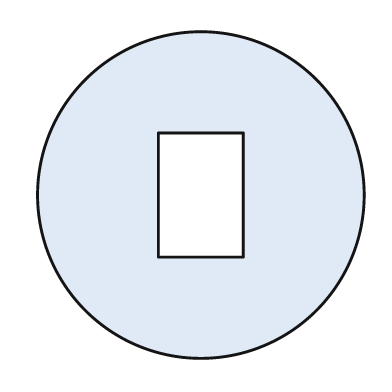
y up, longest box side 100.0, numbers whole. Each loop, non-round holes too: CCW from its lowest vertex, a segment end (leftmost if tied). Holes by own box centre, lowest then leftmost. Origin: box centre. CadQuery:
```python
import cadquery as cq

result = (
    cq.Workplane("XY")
    .moveTo(0.0, 0.0)
    .circle(50.0)
    .moveTo(-13.0, -19.0)
    .lineTo(13.0, -19.0)
    .lineTo(13.0, 19.0)
    .lineTo(-13.0, 19.0)
    .close()
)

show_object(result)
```